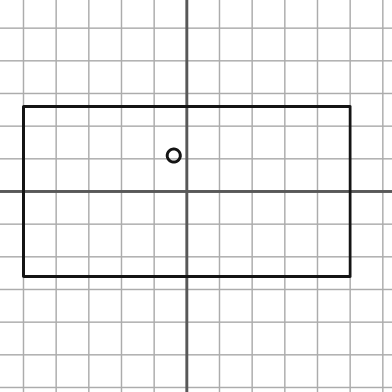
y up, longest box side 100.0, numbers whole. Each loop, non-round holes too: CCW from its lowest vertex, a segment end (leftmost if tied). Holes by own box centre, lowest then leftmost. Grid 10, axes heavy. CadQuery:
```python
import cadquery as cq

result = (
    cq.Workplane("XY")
    .moveTo(-50.0, -26.0)
    .lineTo(50.0, -26.0)
    .lineTo(50.0, 26.0)
    .lineTo(-50.0, 26.0)
    .close()
    .moveTo(-4.0, 11.0)
    .circle(2.0)
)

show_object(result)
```